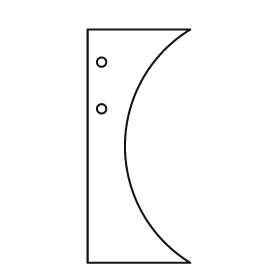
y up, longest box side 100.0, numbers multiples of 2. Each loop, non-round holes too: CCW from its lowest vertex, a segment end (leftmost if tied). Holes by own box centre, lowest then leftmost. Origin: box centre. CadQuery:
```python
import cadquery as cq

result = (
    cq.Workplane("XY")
    .moveTo(-22.0, -50.0)
    .lineTo(22.0, -50.0)
    .threePointArc((-6.0, 0.0), (22.0, 50.0))
    .lineTo(-22.0, 50.0)
    .close()
    .moveTo(-16.0, 16.0)
    .circle(2.0)
    .moveTo(-16.0, 36.0)
    .circle(2.0)
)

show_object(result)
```